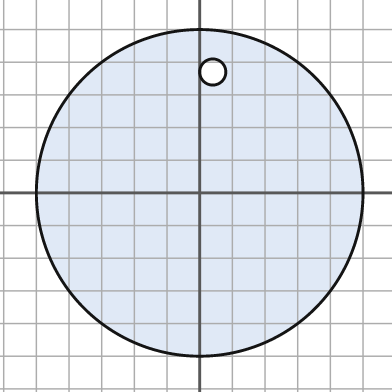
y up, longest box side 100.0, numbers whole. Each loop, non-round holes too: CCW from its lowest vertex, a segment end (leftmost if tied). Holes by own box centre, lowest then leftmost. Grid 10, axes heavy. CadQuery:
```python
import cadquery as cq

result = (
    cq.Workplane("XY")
    .moveTo(0.0, 0.0)
    .circle(50.0)
    .moveTo(4.0, 37.0)
    .circle(4.0)
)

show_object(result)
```